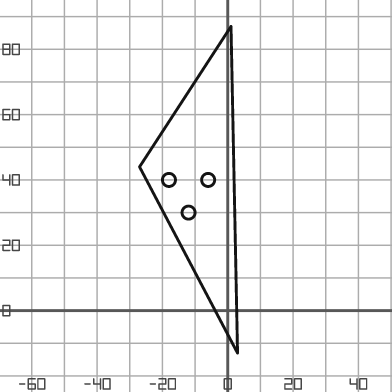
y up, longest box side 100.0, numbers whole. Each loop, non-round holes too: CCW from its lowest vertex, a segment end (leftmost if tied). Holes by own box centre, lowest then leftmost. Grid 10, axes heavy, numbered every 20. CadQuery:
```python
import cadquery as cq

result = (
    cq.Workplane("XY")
    .moveTo(3.0, -13.0)
    .lineTo(1.0, 87.0)
    .lineTo(-27.0, 44.0)
    .close()
    .moveTo(-12.0, 30.0)
    .circle(2.0)
    .moveTo(-18.0, 40.0)
    .circle(2.0)
    .moveTo(-6.0, 40.0)
    .circle(2.0)
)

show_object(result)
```